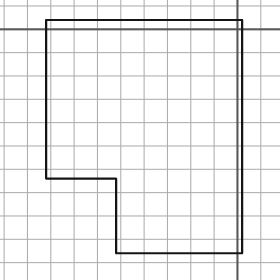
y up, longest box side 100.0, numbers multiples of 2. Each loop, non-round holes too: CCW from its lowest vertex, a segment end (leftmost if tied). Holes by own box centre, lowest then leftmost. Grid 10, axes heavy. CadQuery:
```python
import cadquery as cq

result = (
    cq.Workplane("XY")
    .moveTo(-52.0, -96.0)
    .lineTo(2.0, -96.0)
    .lineTo(2.0, 4.0)
    .lineTo(-82.0, 4.0)
    .lineTo(-82.0, -64.0)
    .lineTo(-52.0, -64.0)
    .close()
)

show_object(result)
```